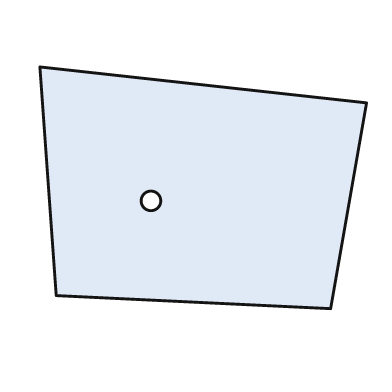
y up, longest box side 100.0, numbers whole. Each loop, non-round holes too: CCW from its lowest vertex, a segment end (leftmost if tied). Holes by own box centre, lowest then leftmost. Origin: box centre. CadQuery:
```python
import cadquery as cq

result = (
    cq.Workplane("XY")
    .moveTo(39.0, -37.0)
    .lineTo(50.0, 26.0)
    .lineTo(-50.0, 37.0)
    .lineTo(-45.0, -33.0)
    .close()
    .moveTo(-16.0, -4.0)
    .circle(3.0)
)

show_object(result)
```